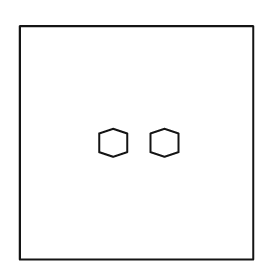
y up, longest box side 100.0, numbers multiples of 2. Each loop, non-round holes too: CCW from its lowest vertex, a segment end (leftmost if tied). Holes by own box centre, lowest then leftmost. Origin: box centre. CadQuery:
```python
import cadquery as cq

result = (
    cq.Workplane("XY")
    .moveTo(-50.0, -50.0)
    .lineTo(50.0, -50.0)
    .lineTo(50.0, 50.0)
    .lineTo(-50.0, 50.0)
    .close()
    .moveTo(-10.0, -6.0)
    .lineTo(-4.0, -4.0)
    .lineTo(-4.0, 4.0)
    .lineTo(-10.0, 6.0)
    .lineTo(-16.0, 4.0)
    .lineTo(-16.0, -4.0)
    .close()
    .moveTo(12.0, -6.0)
    .lineTo(18.0, -4.0)
    .lineTo(18.0, 4.0)
    .lineTo(12.0, 6.0)
    .lineTo(6.0, 4.0)
    .lineTo(6.0, -4.0)
    .close()
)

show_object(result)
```